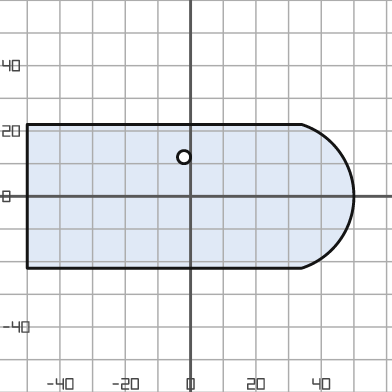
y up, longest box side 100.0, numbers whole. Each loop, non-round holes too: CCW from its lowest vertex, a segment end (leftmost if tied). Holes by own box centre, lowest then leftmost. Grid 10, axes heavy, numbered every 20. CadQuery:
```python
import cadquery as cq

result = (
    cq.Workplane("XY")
    .moveTo(-50.0, -22.0)
    .lineTo(34.0, -22.0)
    .threePointArc((50.0, 0.0), (34.0, 22.0))
    .lineTo(-50.0, 22.0)
    .close()
    .moveTo(-2.0, 12.0)
    .circle(2.0)
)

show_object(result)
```